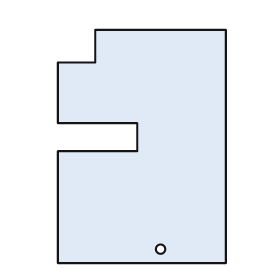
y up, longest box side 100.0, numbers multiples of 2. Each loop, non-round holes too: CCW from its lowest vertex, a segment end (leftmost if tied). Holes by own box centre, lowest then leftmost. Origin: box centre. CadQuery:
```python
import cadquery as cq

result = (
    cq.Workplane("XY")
    .moveTo(-36.0, -50.0)
    .lineTo(36.0, -50.0)
    .lineTo(36.0, 50.0)
    .lineTo(-20.0, 50.0)
    .lineTo(-20.0, 36.0)
    .lineTo(-36.0, 36.0)
    .lineTo(-36.0, 10.0)
    .lineTo(-2.0, 10.0)
    .lineTo(-2.0, -2.0)
    .lineTo(-36.0, -2.0)
    .close()
    .moveTo(8.0, -44.0)
    .circle(2.0)
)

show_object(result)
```